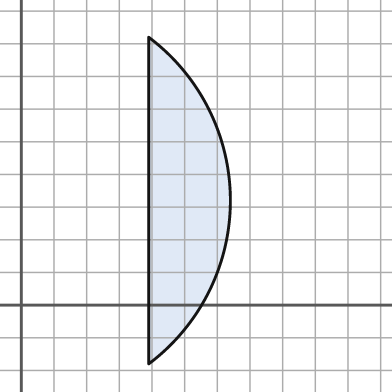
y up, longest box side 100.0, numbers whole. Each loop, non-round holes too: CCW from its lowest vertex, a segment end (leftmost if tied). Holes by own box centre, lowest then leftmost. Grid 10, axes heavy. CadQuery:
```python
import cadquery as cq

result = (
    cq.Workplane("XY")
    .moveTo(39.0, -18.0)
    .threePointArc((64.0, 32.0), (39.0, 82.0))
    .close()
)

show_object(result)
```